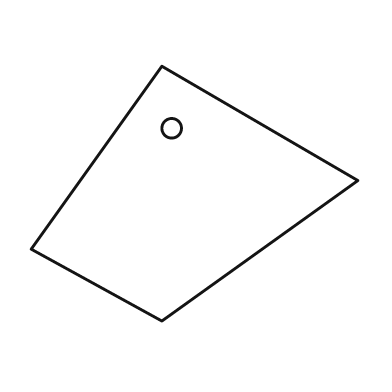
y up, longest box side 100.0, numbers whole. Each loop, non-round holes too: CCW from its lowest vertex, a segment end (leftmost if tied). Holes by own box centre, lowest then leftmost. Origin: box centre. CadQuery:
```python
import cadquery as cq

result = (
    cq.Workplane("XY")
    .moveTo(-10.0, -39.0)
    .lineTo(50.0, 4.0)
    .lineTo(-10.0, 39.0)
    .lineTo(-50.0, -17.0)
    .close()
    .moveTo(-7.0, 20.0)
    .circle(3.0)
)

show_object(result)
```